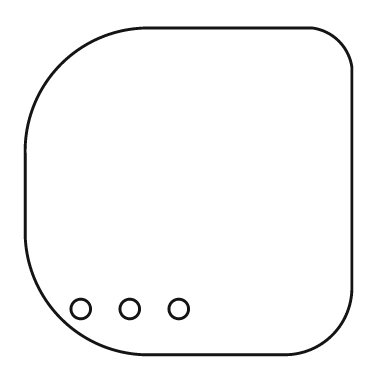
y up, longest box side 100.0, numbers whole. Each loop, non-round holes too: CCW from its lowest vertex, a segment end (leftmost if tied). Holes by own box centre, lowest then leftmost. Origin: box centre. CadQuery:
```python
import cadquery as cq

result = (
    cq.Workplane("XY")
    .moveTo(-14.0, -50.0)
    .lineTo(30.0, -50.0)
    .threePointArc((44.0, -44.0), (50.0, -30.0))
    .lineTo(50.0, 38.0)
    .threePointArc((46.0, 46.0), (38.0, 50.0))
    .lineTo(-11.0, 50.0)
    .threePointArc((-39.0, 39.0), (-50.0, 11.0))
    .lineTo(-50.0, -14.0)
    .threePointArc((-39.0, -39.0), (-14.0, -50.0))
    .close()
    .moveTo(-33.0, -36.0)
    .circle(3.0)
    .moveTo(-18.0, -36.0)
    .circle(3.0)
    .moveTo(-3.0, -36.0)
    .circle(3.0)
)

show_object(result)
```